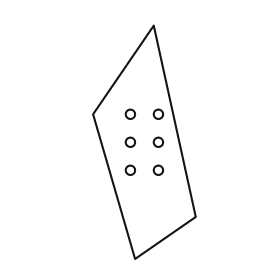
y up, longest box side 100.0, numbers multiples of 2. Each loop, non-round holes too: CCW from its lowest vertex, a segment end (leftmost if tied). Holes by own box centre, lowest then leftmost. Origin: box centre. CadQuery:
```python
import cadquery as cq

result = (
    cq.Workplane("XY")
    .moveTo(-4.0, -50.0)
    .lineTo(22.0, -32.0)
    .lineTo(4.0, 50.0)
    .lineTo(-22.0, 12.0)
    .close()
    .moveTo(-6.0, -12.0)
    .circle(2.0)
    .moveTo(6.0, -12.0)
    .circle(2.0)
    .moveTo(-6.0, 0.0)
    .circle(2.0)
    .moveTo(6.0, 0.0)
    .circle(2.0)
    .moveTo(-6.0, 12.0)
    .circle(2.0)
    .moveTo(6.0, 12.0)
    .circle(2.0)
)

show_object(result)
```